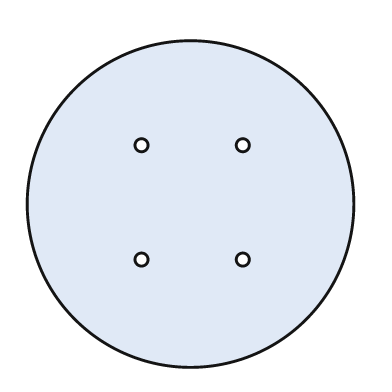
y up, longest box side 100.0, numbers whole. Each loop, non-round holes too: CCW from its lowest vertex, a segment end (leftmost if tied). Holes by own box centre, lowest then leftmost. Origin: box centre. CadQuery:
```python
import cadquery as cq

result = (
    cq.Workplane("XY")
    .moveTo(0.0, 0.0)
    .circle(50.0)
    .moveTo(-15.0, -17.0)
    .circle(2.0)
    .moveTo(16.0, -17.0)
    .circle(2.0)
    .moveTo(-15.0, 18.0)
    .circle(2.0)
    .moveTo(16.0, 18.0)
    .circle(2.0)
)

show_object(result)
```